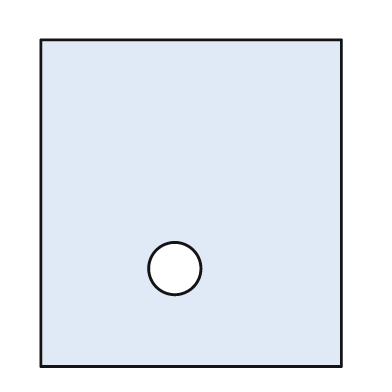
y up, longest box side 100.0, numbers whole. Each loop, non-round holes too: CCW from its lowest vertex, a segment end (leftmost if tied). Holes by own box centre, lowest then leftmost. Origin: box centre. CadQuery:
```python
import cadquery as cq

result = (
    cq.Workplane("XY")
    .moveTo(-46.0, -50.0)
    .lineTo(46.0, -50.0)
    .lineTo(46.0, 50.0)
    .lineTo(-46.0, 50.0)
    .close()
    .moveTo(-5.0, -20.0)
    .circle(8.0)
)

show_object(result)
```